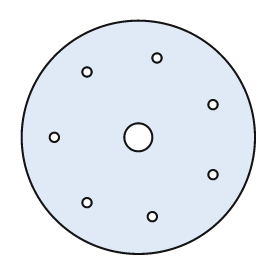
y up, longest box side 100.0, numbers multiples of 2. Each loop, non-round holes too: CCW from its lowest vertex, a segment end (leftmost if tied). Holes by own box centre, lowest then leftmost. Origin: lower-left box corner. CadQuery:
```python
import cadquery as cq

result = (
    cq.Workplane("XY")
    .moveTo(50.0, 50.0)
    .circle(50.0)
    .moveTo(56.0, 16.0)
    .circle(2.0)
    .moveTo(28.0, 22.0)
    .circle(2.0)
    .moveTo(82.0, 34.0)
    .circle(2.0)
    .moveTo(14.0, 50.0)
    .circle(2.0)
    .moveTo(50.0, 50.0)
    .circle(6.0)
    .moveTo(82.0, 64.0)
    .circle(2.0)
    .moveTo(28.0, 78.0)
    .circle(2.0)
    .moveTo(58.0, 84.0)
    .circle(2.0)
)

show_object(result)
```